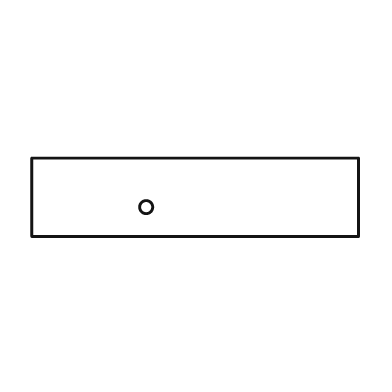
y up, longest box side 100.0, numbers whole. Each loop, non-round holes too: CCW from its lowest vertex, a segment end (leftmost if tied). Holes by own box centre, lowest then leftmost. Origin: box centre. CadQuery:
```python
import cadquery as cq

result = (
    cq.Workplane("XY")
    .moveTo(-50.0, -12.0)
    .lineTo(50.0, -12.0)
    .lineTo(50.0, 12.0)
    .lineTo(-50.0, 12.0)
    .close()
    .moveTo(-15.0, -3.0)
    .circle(2.0)
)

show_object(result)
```